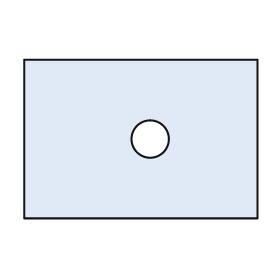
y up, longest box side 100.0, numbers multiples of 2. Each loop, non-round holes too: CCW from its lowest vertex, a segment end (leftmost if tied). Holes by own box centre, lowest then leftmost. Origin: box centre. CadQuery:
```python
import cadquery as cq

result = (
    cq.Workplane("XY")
    .moveTo(-50.0, -34.0)
    .lineTo(50.0, -34.0)
    .lineTo(50.0, 34.0)
    .lineTo(-50.0, 34.0)
    .close()
    .moveTo(4.0, 0.0)
    .circle(8.0)
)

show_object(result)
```